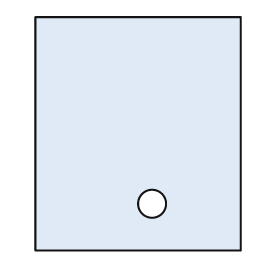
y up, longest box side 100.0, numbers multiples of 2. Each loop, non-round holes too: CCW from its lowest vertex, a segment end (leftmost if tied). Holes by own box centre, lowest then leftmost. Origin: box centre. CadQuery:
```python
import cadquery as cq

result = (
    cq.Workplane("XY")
    .moveTo(-44.0, -50.0)
    .lineTo(44.0, -50.0)
    .lineTo(44.0, 50.0)
    .lineTo(-44.0, 50.0)
    .close()
    .moveTo(6.0, -30.0)
    .circle(6.0)
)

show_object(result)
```